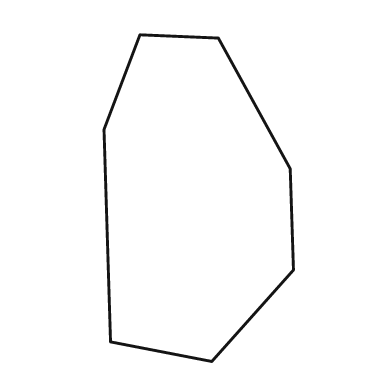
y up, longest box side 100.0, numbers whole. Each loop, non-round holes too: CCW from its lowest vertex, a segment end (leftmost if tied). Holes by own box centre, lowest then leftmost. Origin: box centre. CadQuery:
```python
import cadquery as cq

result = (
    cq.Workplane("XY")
    .moveTo(4.0, -50.0)
    .lineTo(29.0, -22.0)
    .lineTo(28.0, 9.0)
    .lineTo(6.0, 49.0)
    .lineTo(-18.0, 50.0)
    .lineTo(-29.0, 21.0)
    .lineTo(-27.0, -44.0)
    .close()
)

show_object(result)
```